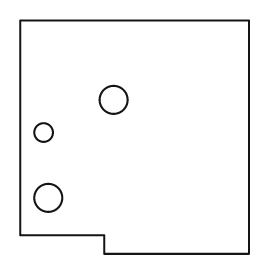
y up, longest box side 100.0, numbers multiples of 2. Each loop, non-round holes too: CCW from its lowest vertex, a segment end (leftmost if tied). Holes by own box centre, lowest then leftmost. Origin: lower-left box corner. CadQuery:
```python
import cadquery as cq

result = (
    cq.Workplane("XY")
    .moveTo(36.0, 0.0)
    .lineTo(98.0, 0.0)
    .lineTo(98.0, 100.0)
    .lineTo(0.0, 100.0)
    .lineTo(0.0, 8.0)
    .lineTo(36.0, 8.0)
    .close()
    .moveTo(12.0, 24.0)
    .circle(6.0)
    .moveTo(10.0, 52.0)
    .circle(4.0)
    .moveTo(40.0, 66.0)
    .circle(6.0)
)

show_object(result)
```